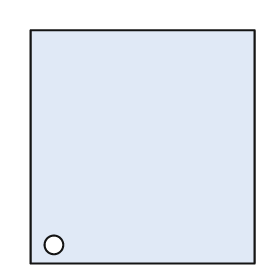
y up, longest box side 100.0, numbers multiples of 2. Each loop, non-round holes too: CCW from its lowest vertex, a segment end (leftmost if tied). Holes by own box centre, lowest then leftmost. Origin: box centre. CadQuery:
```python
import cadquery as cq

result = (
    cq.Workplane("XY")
    .moveTo(-48.0, -50.0)
    .lineTo(48.0, -50.0)
    .lineTo(48.0, 50.0)
    .lineTo(-48.0, 50.0)
    .close()
    .moveTo(-38.0, -42.0)
    .circle(4.0)
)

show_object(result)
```